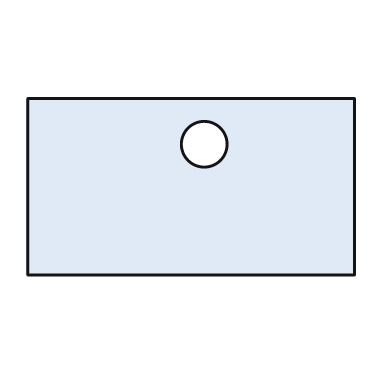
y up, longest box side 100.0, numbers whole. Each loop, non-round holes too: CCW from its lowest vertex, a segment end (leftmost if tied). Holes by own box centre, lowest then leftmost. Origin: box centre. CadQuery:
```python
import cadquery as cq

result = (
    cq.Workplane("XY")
    .moveTo(-50.0, -27.0)
    .lineTo(50.0, -27.0)
    .lineTo(50.0, 27.0)
    .lineTo(-50.0, 27.0)
    .close()
    .moveTo(4.0, 13.0)
    .circle(7.0)
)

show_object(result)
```